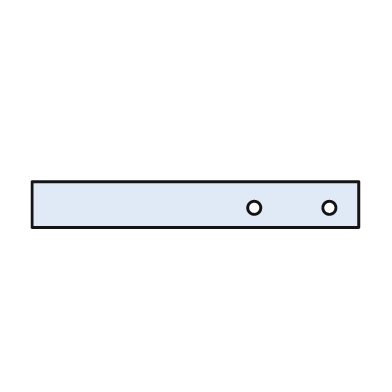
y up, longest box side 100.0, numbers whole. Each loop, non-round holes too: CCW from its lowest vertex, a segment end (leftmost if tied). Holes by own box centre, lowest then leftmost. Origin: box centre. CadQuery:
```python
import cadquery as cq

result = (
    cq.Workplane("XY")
    .moveTo(-50.0, -7.0)
    .lineTo(50.0, -7.0)
    .lineTo(50.0, 7.0)
    .lineTo(-50.0, 7.0)
    .close()
    .moveTo(18.0, -1.0)
    .circle(2.0)
    .moveTo(41.0, -1.0)
    .circle(2.0)
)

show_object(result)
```